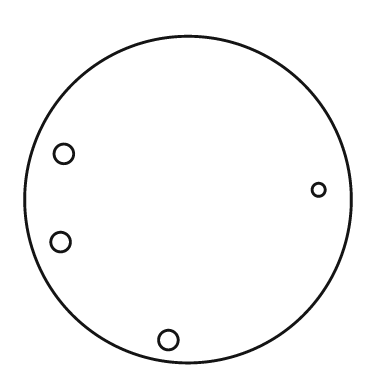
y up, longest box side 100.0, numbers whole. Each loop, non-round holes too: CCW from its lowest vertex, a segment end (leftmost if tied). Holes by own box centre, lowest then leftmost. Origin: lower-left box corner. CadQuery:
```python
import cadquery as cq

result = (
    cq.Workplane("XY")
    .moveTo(50.0, 50.0)
    .circle(50.0)
    .moveTo(44.0, 7.0)
    .circle(3.0)
    .moveTo(11.0, 37.0)
    .circle(3.0)
    .moveTo(90.0, 53.0)
    .circle(2.0)
    .moveTo(12.0, 64.0)
    .circle(3.0)
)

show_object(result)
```